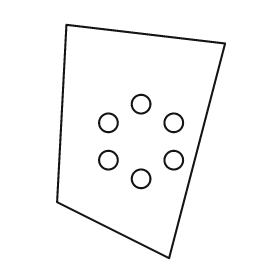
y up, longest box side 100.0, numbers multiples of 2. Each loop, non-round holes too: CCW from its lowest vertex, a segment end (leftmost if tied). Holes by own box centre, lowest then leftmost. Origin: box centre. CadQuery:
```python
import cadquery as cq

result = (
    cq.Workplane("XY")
    .moveTo(12.0, -50.0)
    .lineTo(36.0, 42.0)
    .lineTo(-32.0, 50.0)
    .lineTo(-36.0, -26.0)
    .close()
    .moveTo(0.0, -16.0)
    .circle(4.0)
    .moveTo(-14.0, -8.0)
    .circle(4.0)
    .moveTo(14.0, -8.0)
    .circle(4.0)
    .moveTo(-14.0, 8.0)
    .circle(4.0)
    .moveTo(14.0, 8.0)
    .circle(4.0)
    .moveTo(0.0, 16.0)
    .circle(4.0)
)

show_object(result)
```